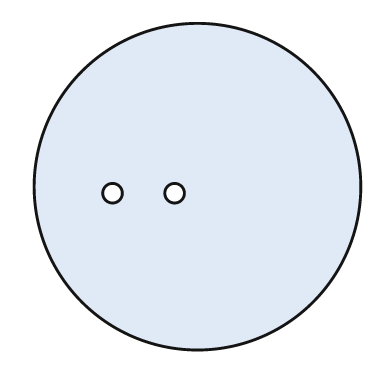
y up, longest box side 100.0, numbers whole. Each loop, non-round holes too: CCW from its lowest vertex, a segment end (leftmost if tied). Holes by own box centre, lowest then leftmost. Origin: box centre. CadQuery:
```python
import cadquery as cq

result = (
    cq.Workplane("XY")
    .moveTo(0.0, 0.0)
    .circle(50.0)
    .moveTo(-26.0, -2.0)
    .circle(3.0)
    .moveTo(-7.0, -2.0)
    .circle(3.0)
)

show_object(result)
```